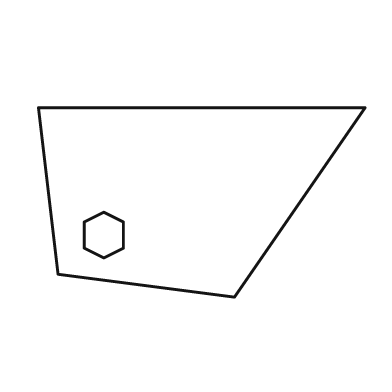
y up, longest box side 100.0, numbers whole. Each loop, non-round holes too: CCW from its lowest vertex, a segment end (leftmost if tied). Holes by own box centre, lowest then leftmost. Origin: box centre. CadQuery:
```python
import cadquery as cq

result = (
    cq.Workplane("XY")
    .moveTo(10.0, -29.0)
    .lineTo(50.0, 29.0)
    .lineTo(-50.0, 29.0)
    .lineTo(-44.0, -22.0)
    .close()
    .moveTo(-30.0, -17.0)
    .lineTo(-24.0, -14.0)
    .lineTo(-24.0, -6.0)
    .lineTo(-30.0, -3.0)
    .lineTo(-36.0, -6.0)
    .lineTo(-36.0, -14.0)
    .close()
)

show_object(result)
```